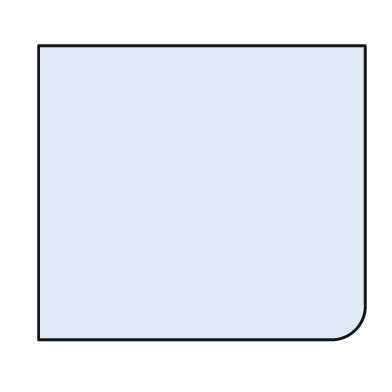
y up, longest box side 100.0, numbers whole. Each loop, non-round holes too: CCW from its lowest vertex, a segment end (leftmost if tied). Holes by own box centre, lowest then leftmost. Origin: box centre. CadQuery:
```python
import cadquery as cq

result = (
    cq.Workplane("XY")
    .moveTo(-50.0, -45.0)
    .lineTo(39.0, -45.0)
    .threePointArc((47.0, -42.0), (50.0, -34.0))
    .lineTo(50.0, 45.0)
    .lineTo(-50.0, 45.0)
    .close()
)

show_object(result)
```